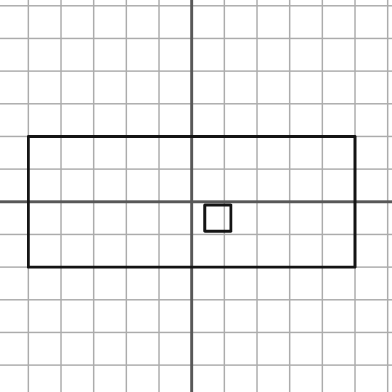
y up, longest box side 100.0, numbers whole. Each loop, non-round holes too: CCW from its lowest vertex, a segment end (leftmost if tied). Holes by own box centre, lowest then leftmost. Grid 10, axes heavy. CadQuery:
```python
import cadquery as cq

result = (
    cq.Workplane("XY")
    .moveTo(-50.0, -20.0)
    .lineTo(50.0, -20.0)
    .lineTo(50.0, 20.0)
    .lineTo(-50.0, 20.0)
    .close()
    .moveTo(4.0, -9.0)
    .lineTo(12.0, -9.0)
    .lineTo(12.0, -1.0)
    .lineTo(4.0, -1.0)
    .close()
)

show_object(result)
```